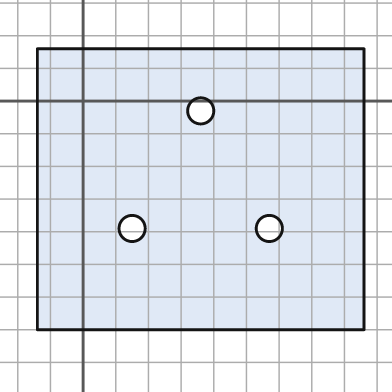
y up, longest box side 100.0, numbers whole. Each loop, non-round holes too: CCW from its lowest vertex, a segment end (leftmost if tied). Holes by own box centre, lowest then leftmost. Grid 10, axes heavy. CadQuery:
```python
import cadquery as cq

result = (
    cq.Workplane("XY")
    .moveTo(-14.0, -70.0)
    .lineTo(86.0, -70.0)
    .lineTo(86.0, 16.0)
    .lineTo(-14.0, 16.0)
    .close()
    .moveTo(15.0, -39.0)
    .circle(4.0)
    .moveTo(57.0, -39.0)
    .circle(4.0)
    .moveTo(36.0, -3.0)
    .circle(4.0)
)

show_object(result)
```